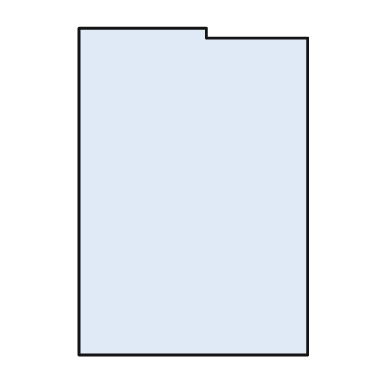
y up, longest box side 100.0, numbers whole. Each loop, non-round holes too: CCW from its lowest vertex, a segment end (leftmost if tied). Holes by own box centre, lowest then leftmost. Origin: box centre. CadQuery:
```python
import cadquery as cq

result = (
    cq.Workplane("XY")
    .moveTo(-35.0, -50.0)
    .lineTo(35.0, -50.0)
    .lineTo(35.0, 47.0)
    .lineTo(4.0, 47.0)
    .lineTo(4.0, 50.0)
    .lineTo(-35.0, 50.0)
    .close()
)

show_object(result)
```